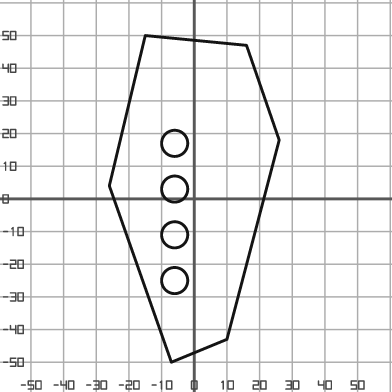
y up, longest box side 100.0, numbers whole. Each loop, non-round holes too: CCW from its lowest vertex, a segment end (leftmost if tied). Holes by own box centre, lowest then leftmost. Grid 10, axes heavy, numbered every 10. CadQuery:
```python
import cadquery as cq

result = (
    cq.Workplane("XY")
    .moveTo(-7.0, -50.0)
    .lineTo(10.0, -43.0)
    .lineTo(26.0, 18.0)
    .lineTo(16.0, 47.0)
    .lineTo(-15.0, 50.0)
    .lineTo(-26.0, 4.0)
    .close()
    .moveTo(-6.0, -25.0)
    .circle(4.0)
    .moveTo(-6.0, -11.0)
    .circle(4.0)
    .moveTo(-6.0, 3.0)
    .circle(4.0)
    .moveTo(-6.0, 17.0)
    .circle(4.0)
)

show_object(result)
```